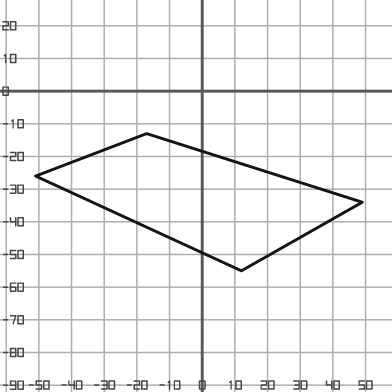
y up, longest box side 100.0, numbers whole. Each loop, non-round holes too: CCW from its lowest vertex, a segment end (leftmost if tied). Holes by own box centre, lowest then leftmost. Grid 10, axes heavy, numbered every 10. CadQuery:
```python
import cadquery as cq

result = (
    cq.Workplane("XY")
    .moveTo(12.0, -55.0)
    .lineTo(49.0, -34.0)
    .lineTo(-17.0, -13.0)
    .lineTo(-51.0, -26.0)
    .close()
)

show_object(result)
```